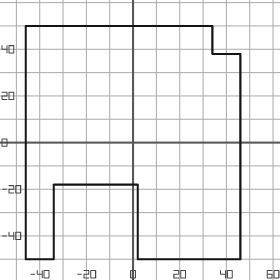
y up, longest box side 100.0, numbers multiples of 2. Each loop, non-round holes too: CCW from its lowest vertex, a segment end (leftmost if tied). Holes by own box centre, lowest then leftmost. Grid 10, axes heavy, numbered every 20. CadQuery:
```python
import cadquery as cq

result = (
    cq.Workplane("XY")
    .moveTo(-46.0, -50.0)
    .lineTo(-34.0, -50.0)
    .lineTo(-34.0, -18.0)
    .lineTo(2.0, -18.0)
    .lineTo(2.0, -50.0)
    .lineTo(46.0, -50.0)
    .lineTo(46.0, 38.0)
    .lineTo(34.0, 38.0)
    .lineTo(34.0, 50.0)
    .lineTo(-46.0, 50.0)
    .close()
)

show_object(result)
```